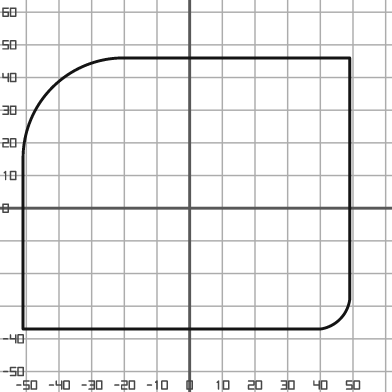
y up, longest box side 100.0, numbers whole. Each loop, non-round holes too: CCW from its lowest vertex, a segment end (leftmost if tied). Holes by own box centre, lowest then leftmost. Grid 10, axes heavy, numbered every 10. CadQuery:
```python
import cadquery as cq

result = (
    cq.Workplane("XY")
    .moveTo(-51.0, -37.0)
    .lineTo(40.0, -37.0)
    .threePointArc((46.0, -34.0), (49.0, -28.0))
    .lineTo(49.0, 46.0)
    .lineTo(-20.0, 46.0)
    .threePointArc((-42.0, 37.0), (-51.0, 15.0))
    .close()
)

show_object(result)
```